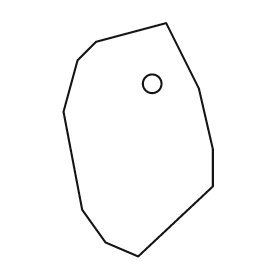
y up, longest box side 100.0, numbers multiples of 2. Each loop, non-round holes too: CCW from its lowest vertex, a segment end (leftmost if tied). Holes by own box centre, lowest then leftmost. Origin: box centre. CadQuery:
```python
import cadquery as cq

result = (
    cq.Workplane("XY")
    .moveTo(0.0, -50.0)
    .lineTo(32.0, -20.0)
    .lineTo(32.0, -4.0)
    .lineTo(26.0, 22.0)
    .lineTo(12.0, 50.0)
    .lineTo(-18.0, 42.0)
    .lineTo(-26.0, 34.0)
    .lineTo(-32.0, 12.0)
    .lineTo(-24.0, -30.0)
    .lineTo(-14.0, -44.0)
    .close()
    .moveTo(6.0, 24.0)
    .circle(4.0)
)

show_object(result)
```